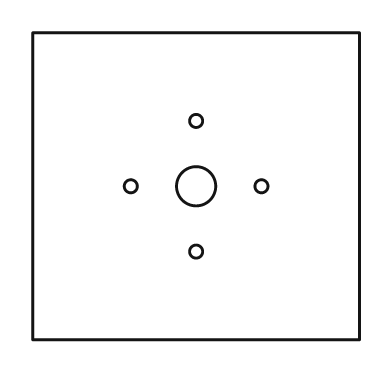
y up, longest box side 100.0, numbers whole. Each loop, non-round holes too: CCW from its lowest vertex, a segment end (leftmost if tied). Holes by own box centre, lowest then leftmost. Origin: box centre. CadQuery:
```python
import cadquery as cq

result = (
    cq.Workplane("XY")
    .moveTo(-50.0, -47.0)
    .lineTo(50.0, -47.0)
    .lineTo(50.0, 47.0)
    .lineTo(-50.0, 47.0)
    .close()
    .moveTo(0.0, -20.0)
    .circle(2.0)
    .moveTo(-20.0, 0.0)
    .circle(2.0)
    .moveTo(0.0, 0.0)
    .circle(6.0)
    .moveTo(20.0, 0.0)
    .circle(2.0)
    .moveTo(0.0, 20.0)
    .circle(2.0)
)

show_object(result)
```